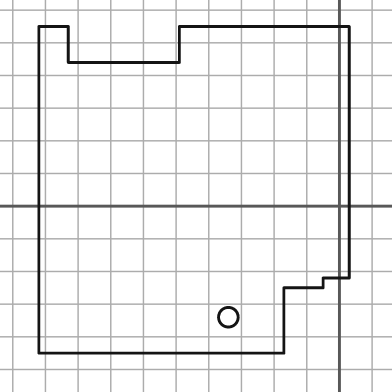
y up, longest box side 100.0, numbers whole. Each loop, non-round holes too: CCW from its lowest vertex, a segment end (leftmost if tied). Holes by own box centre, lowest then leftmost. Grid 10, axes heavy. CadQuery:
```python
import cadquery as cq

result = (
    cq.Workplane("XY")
    .moveTo(-92.0, -45.0)
    .lineTo(-17.0, -45.0)
    .lineTo(-17.0, -25.0)
    .lineTo(-5.0, -25.0)
    .lineTo(-5.0, -22.0)
    .lineTo(3.0, -22.0)
    .lineTo(3.0, 55.0)
    .lineTo(-49.0, 55.0)
    .lineTo(-49.0, 44.0)
    .lineTo(-83.0, 44.0)
    .lineTo(-83.0, 55.0)
    .lineTo(-92.0, 55.0)
    .close()
    .moveTo(-34.0, -34.0)
    .circle(3.0)
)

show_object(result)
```